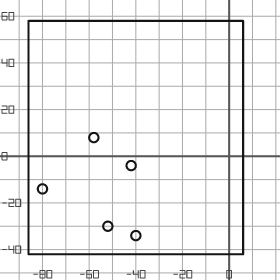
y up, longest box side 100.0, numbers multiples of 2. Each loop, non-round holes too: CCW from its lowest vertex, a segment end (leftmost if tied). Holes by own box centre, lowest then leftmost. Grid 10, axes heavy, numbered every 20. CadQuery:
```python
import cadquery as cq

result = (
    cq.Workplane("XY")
    .moveTo(-86.0, -42.0)
    .lineTo(6.0, -42.0)
    .lineTo(6.0, 58.0)
    .lineTo(-86.0, 58.0)
    .close()
    .moveTo(-40.0, -34.0)
    .circle(2.0)
    .moveTo(-52.0, -30.0)
    .circle(2.0)
    .moveTo(-80.0, -14.0)
    .circle(2.0)
    .moveTo(-42.0, -4.0)
    .circle(2.0)
    .moveTo(-58.0, 8.0)
    .circle(2.0)
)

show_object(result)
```